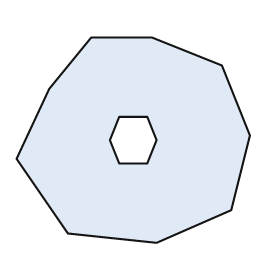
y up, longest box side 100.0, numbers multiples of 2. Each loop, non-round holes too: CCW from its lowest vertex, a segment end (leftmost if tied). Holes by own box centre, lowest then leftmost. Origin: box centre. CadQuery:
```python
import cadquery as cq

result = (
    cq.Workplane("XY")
    .moveTo(10.0, -44.0)
    .lineTo(42.0, -30.0)
    .lineTo(50.0, 2.0)
    .lineTo(38.0, 32.0)
    .lineTo(8.0, 44.0)
    .lineTo(-18.0, 44.0)
    .lineTo(-36.0, 22.0)
    .lineTo(-50.0, -8.0)
    .lineTo(-28.0, -40.0)
    .close()
    .moveTo(-6.0, -10.0)
    .lineTo(6.0, -10.0)
    .lineTo(10.0, 0.0)
    .lineTo(6.0, 10.0)
    .lineTo(-6.0, 10.0)
    .lineTo(-10.0, 0.0)
    .close()
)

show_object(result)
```